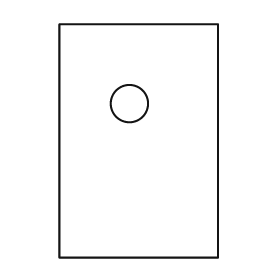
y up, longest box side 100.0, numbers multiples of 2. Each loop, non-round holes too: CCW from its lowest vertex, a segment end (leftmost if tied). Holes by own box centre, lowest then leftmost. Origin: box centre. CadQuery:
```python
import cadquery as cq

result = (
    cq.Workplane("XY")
    .moveTo(-34.0, -50.0)
    .lineTo(34.0, -50.0)
    .lineTo(34.0, 50.0)
    .lineTo(-34.0, 50.0)
    .close()
    .moveTo(-4.0, 16.0)
    .circle(8.0)
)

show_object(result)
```